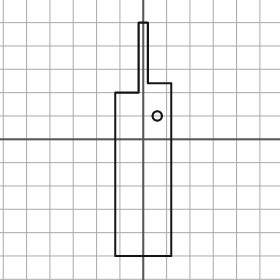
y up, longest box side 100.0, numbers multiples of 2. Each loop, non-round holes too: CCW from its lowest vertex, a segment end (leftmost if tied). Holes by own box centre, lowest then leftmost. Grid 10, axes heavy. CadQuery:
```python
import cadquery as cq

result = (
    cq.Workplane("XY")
    .moveTo(-12.0, -50.0)
    .lineTo(12.0, -50.0)
    .lineTo(12.0, 24.0)
    .lineTo(2.0, 24.0)
    .lineTo(2.0, 50.0)
    .lineTo(-2.0, 50.0)
    .lineTo(-2.0, 20.0)
    .lineTo(-12.0, 20.0)
    .close()
    .moveTo(6.0, 10.0)
    .circle(2.0)
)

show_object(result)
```